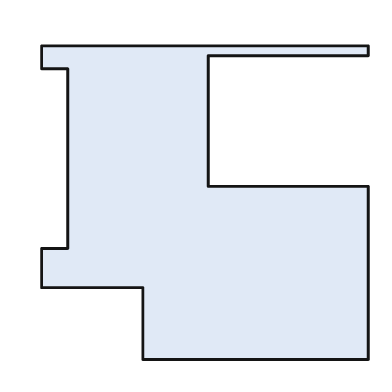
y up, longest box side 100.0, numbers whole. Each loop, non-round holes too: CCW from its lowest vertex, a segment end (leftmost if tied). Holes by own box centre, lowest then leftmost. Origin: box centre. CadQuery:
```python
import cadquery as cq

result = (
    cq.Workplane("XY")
    .moveTo(-19.0, -48.0)
    .lineTo(50.0, -48.0)
    .lineTo(50.0, 5.0)
    .lineTo(1.0, 5.0)
    .lineTo(1.0, 45.0)
    .lineTo(50.0, 45.0)
    .lineTo(50.0, 48.0)
    .lineTo(-50.0, 48.0)
    .lineTo(-50.0, 41.0)
    .lineTo(-42.0, 41.0)
    .lineTo(-42.0, -14.0)
    .lineTo(-50.0, -14.0)
    .lineTo(-50.0, -26.0)
    .lineTo(-19.0, -26.0)
    .close()
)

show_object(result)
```